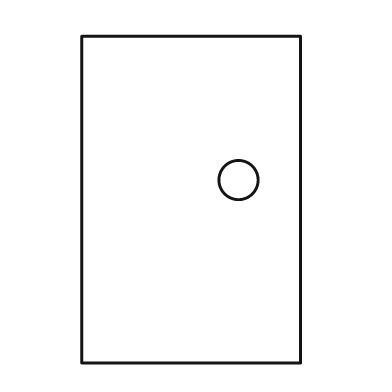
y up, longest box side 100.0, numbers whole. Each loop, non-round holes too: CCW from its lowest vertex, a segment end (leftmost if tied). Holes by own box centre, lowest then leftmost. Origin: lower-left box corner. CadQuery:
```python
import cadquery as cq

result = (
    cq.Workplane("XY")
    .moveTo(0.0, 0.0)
    .lineTo(67.0, 0.0)
    .lineTo(67.0, 100.0)
    .lineTo(0.0, 100.0)
    .close()
    .moveTo(48.0, 56.0)
    .circle(6.0)
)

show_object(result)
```